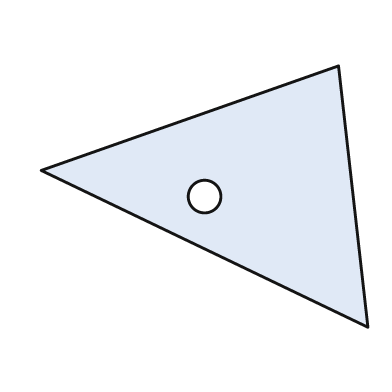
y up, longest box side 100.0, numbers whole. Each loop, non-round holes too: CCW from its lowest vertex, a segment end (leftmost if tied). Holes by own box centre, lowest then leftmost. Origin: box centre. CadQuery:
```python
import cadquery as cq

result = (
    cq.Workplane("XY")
    .moveTo(50.0, -40.0)
    .lineTo(41.0, 40.0)
    .lineTo(-50.0, 8.0)
    .close()
    .moveTo(0.0, 0.0)
    .circle(5.0)
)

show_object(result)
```